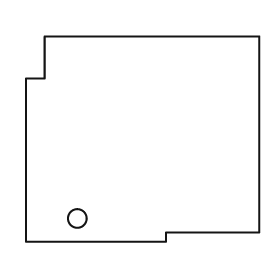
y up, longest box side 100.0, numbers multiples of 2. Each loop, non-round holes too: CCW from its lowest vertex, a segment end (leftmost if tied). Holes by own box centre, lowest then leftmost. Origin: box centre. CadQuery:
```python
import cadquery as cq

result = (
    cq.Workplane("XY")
    .moveTo(-50.0, -44.0)
    .lineTo(10.0, -44.0)
    .lineTo(10.0, -40.0)
    .lineTo(50.0, -40.0)
    .lineTo(50.0, 44.0)
    .lineTo(-42.0, 44.0)
    .lineTo(-42.0, 26.0)
    .lineTo(-50.0, 26.0)
    .close()
    .moveTo(-28.0, -34.0)
    .circle(4.0)
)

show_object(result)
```